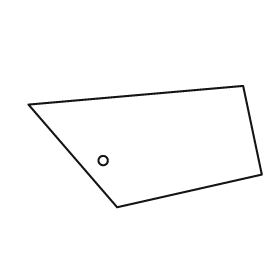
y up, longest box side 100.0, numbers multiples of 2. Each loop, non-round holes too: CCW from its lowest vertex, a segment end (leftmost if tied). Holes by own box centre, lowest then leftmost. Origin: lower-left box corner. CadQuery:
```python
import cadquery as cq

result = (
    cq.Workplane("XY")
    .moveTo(38.0, 0.0)
    .lineTo(100.0, 14.0)
    .lineTo(92.0, 52.0)
    .lineTo(0.0, 44.0)
    .close()
    .moveTo(32.0, 20.0)
    .circle(2.0)
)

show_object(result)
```